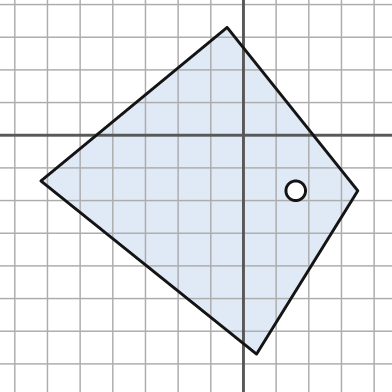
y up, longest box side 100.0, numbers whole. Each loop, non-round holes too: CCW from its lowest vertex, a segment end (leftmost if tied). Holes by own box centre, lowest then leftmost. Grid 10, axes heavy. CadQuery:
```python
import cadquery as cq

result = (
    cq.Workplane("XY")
    .moveTo(4.0, -67.0)
    .lineTo(35.0, -17.0)
    .lineTo(-5.0, 33.0)
    .lineTo(-62.0, -14.0)
    .close()
    .moveTo(16.0, -17.0)
    .circle(3.0)
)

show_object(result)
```